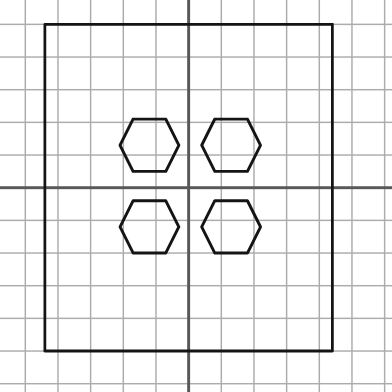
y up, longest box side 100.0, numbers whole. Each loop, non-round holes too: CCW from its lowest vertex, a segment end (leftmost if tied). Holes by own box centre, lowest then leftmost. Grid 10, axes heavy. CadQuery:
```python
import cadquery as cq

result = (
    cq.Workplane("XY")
    .moveTo(-44.0, -50.0)
    .lineTo(44.0, -50.0)
    .lineTo(44.0, 50.0)
    .lineTo(-44.0, 50.0)
    .close()
    .moveTo(-17.0, -20.0)
    .lineTo(-7.0, -20.0)
    .lineTo(-3.0, -12.0)
    .lineTo(-7.0, -4.0)
    .lineTo(-17.0, -4.0)
    .lineTo(-21.0, -12.0)
    .close()
    .moveTo(8.0, -20.0)
    .lineTo(18.0, -20.0)
    .lineTo(22.0, -12.0)
    .lineTo(18.0, -4.0)
    .lineTo(8.0, -4.0)
    .lineTo(4.0, -12.0)
    .close()
    .moveTo(-17.0, 5.0)
    .lineTo(-7.0, 5.0)
    .lineTo(-3.0, 13.0)
    .lineTo(-7.0, 21.0)
    .lineTo(-17.0, 21.0)
    .lineTo(-21.0, 13.0)
    .close()
    .moveTo(8.0, 5.0)
    .lineTo(18.0, 5.0)
    .lineTo(22.0, 13.0)
    .lineTo(18.0, 21.0)
    .lineTo(8.0, 21.0)
    .lineTo(4.0, 13.0)
    .close()
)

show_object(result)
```